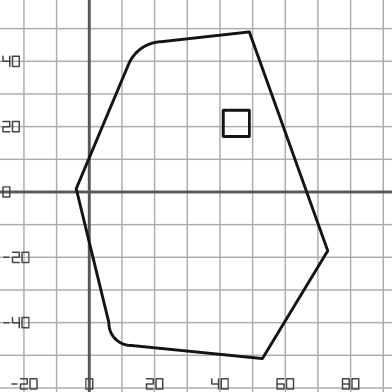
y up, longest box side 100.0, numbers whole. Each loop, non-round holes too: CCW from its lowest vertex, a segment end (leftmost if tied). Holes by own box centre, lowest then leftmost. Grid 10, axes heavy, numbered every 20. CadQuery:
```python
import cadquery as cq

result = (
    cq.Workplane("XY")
    .moveTo(53.0, -51.0)
    .lineTo(73.0, -18.0)
    .lineTo(49.0, 49.0)
    .lineTo(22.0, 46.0)
    .threePointArc((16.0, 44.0), (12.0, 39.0))
    .lineTo(-4.0, 1.0)
    .lineTo(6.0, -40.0)
    .threePointArc((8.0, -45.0), (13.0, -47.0))
    .close()
    .moveTo(41.0, 17.0)
    .lineTo(49.0, 17.0)
    .lineTo(49.0, 25.0)
    .lineTo(41.0, 25.0)
    .close()
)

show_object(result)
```